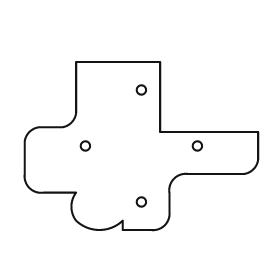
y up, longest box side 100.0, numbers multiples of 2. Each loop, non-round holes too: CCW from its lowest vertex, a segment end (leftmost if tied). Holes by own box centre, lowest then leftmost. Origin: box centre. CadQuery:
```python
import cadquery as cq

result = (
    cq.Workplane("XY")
    .moveTo(-8.0, -36.0)
    .lineTo(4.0, -36.0)
    .threePointArc((10.0, -34.0), (12.0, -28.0))
    .lineTo(12.0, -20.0)
    .threePointArc((14.0, -14.0), (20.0, -12.0))
    .lineTo(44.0, -12.0)
    .threePointArc((48.0, -10.0), (50.0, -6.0))
    .lineTo(50.0, 6.0)
    .lineTo(8.0, 6.0)
    .lineTo(8.0, 36.0)
    .lineTo(-28.0, 36.0)
    .lineTo(-28.0, 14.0)
    .threePointArc((-30.0, 10.0), (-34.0, 8.0))
    .lineTo(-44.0, 8.0)
    .threePointArc((-48.0, 6.0), (-50.0, 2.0))
    .lineTo(-50.0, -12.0)
    .threePointArc((-48.0, -18.0), (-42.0, -20.0))
    .lineTo(-28.0, -20.0)
    .threePointArc((-30.0, -26.0), (-28.0, -32.0))
    .threePointArc((-18.0, -36.0), (-8.0, -32.0))
    .close()
    .moveTo(0.0, -24.0)
    .circle(2.0)
    .moveTo(-24.0, 0.0)
    .circle(2.0)
    .moveTo(24.0, 0.0)
    .circle(2.0)
    .moveTo(0.0, 24.0)
    .circle(2.0)
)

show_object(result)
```